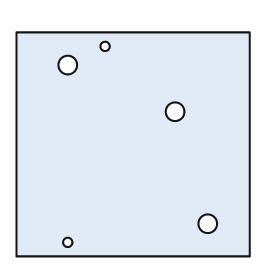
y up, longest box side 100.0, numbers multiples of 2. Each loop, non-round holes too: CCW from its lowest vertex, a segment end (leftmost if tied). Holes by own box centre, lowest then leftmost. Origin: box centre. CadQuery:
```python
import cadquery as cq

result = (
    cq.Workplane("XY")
    .moveTo(-50.0, -48.0)
    .lineTo(50.0, -48.0)
    .lineTo(50.0, 48.0)
    .lineTo(-50.0, 48.0)
    .close()
    .moveTo(-28.0, -42.0)
    .circle(2.0)
    .moveTo(32.0, -34.0)
    .circle(4.0)
    .moveTo(18.0, 14.0)
    .circle(4.0)
    .moveTo(-28.0, 34.0)
    .circle(4.0)
    .moveTo(-12.0, 42.0)
    .circle(2.0)
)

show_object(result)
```